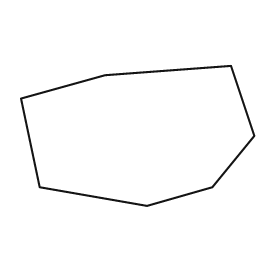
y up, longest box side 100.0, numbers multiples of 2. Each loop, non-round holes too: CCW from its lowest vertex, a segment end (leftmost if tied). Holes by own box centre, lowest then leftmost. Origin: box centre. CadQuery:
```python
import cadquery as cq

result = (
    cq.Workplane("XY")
    .moveTo(4.0, -30.0)
    .lineTo(32.0, -22.0)
    .lineTo(50.0, 0.0)
    .lineTo(40.0, 30.0)
    .lineTo(-14.0, 26.0)
    .lineTo(-50.0, 16.0)
    .lineTo(-42.0, -22.0)
    .close()
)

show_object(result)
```